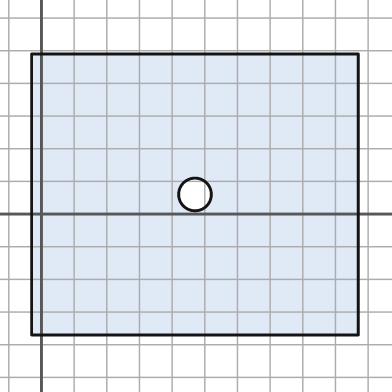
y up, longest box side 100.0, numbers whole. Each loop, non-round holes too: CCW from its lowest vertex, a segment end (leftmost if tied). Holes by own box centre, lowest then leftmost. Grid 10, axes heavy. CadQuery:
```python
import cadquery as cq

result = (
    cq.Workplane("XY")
    .moveTo(-3.0, -37.0)
    .lineTo(97.0, -37.0)
    .lineTo(97.0, 49.0)
    .lineTo(-3.0, 49.0)
    .close()
    .moveTo(47.0, 6.0)
    .circle(5.0)
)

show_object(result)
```